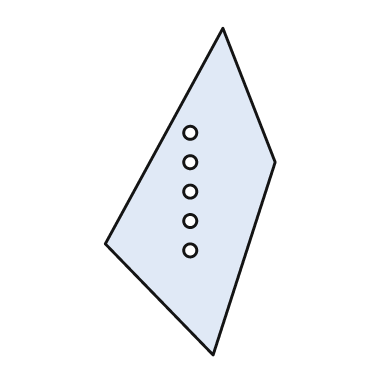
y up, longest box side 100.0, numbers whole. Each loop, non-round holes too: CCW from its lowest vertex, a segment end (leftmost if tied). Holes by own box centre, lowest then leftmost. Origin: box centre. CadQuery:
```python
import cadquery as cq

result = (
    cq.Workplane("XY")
    .moveTo(7.0, -50.0)
    .lineTo(26.0, 9.0)
    .lineTo(10.0, 50.0)
    .lineTo(-26.0, -16.0)
    .close()
    .moveTo(0.0, -18.0)
    .circle(2.0)
    .moveTo(0.0, -9.0)
    .circle(2.0)
    .moveTo(0.0, 0.0)
    .circle(2.0)
    .moveTo(0.0, 9.0)
    .circle(2.0)
    .moveTo(0.0, 18.0)
    .circle(2.0)
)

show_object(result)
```